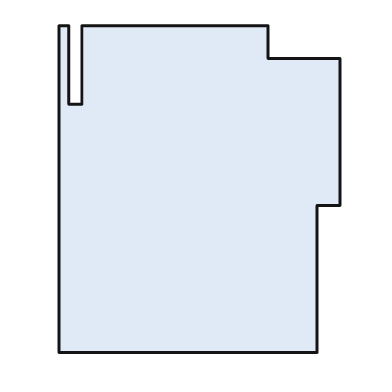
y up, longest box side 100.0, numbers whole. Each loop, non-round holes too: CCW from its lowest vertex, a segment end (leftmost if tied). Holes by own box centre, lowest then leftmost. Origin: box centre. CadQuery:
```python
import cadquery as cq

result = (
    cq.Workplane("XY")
    .moveTo(-43.0, -50.0)
    .lineTo(36.0, -50.0)
    .lineTo(36.0, -5.0)
    .lineTo(43.0, -5.0)
    .lineTo(43.0, 40.0)
    .lineTo(21.0, 40.0)
    .lineTo(21.0, 50.0)
    .lineTo(-36.0, 50.0)
    .lineTo(-36.0, 26.0)
    .lineTo(-40.0, 26.0)
    .lineTo(-40.0, 50.0)
    .lineTo(-43.0, 50.0)
    .close()
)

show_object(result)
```